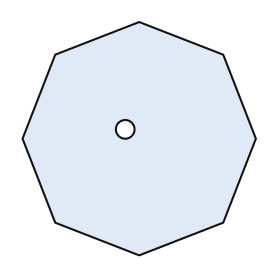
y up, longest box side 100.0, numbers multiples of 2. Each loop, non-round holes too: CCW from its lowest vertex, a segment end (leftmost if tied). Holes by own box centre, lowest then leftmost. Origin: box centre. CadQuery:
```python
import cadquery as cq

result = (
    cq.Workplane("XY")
    .moveTo(0.0, -50.0)
    .lineTo(36.0, -36.0)
    .lineTo(50.0, 0.0)
    .lineTo(36.0, 36.0)
    .lineTo(0.0, 50.0)
    .lineTo(-36.0, 36.0)
    .lineTo(-50.0, 0.0)
    .lineTo(-36.0, -36.0)
    .close()
    .moveTo(-6.0, 4.0)
    .circle(4.0)
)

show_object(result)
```